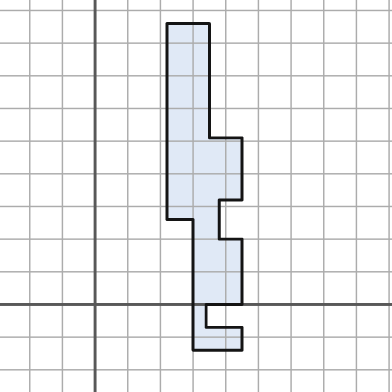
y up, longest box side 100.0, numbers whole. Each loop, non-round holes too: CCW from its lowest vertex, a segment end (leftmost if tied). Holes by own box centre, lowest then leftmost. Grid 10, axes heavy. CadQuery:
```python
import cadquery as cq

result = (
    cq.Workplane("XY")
    .moveTo(30.0, -14.0)
    .lineTo(45.0, -14.0)
    .lineTo(45.0, -7.0)
    .lineTo(34.0, -7.0)
    .lineTo(34.0, 0.0)
    .lineTo(45.0, 0.0)
    .lineTo(45.0, 20.0)
    .lineTo(38.0, 20.0)
    .lineTo(38.0, 32.0)
    .lineTo(45.0, 32.0)
    .lineTo(45.0, 51.0)
    .lineTo(35.0, 51.0)
    .lineTo(35.0, 86.0)
    .lineTo(22.0, 86.0)
    .lineTo(22.0, 26.0)
    .lineTo(30.0, 26.0)
    .close()
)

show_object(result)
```